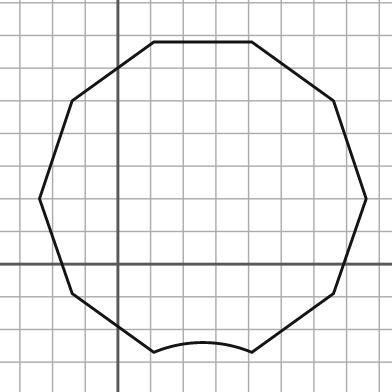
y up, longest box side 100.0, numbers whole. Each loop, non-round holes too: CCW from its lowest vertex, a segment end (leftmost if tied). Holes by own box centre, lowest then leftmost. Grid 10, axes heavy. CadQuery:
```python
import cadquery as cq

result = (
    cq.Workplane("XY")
    .moveTo(11.0, -27.0)
    .threePointArc((26.0, -24.0), (41.0, -27.0))
    .lineTo(66.0, -9.0)
    .lineTo(76.0, 20.0)
    .lineTo(66.0, 50.0)
    .lineTo(41.0, 68.0)
    .lineTo(11.0, 68.0)
    .lineTo(-14.0, 50.0)
    .lineTo(-24.0, 20.0)
    .lineTo(-14.0, -9.0)
    .close()
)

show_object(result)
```